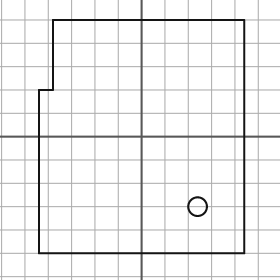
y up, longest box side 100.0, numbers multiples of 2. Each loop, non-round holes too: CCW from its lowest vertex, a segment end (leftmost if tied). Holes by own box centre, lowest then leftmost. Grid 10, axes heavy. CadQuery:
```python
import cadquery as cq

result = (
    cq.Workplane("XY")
    .moveTo(-44.0, -50.0)
    .lineTo(44.0, -50.0)
    .lineTo(44.0, 50.0)
    .lineTo(-38.0, 50.0)
    .lineTo(-38.0, 20.0)
    .lineTo(-44.0, 20.0)
    .close()
    .moveTo(24.0, -30.0)
    .circle(4.0)
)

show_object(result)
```